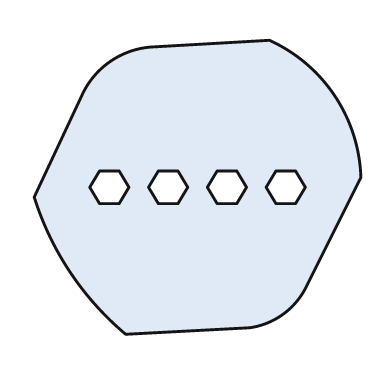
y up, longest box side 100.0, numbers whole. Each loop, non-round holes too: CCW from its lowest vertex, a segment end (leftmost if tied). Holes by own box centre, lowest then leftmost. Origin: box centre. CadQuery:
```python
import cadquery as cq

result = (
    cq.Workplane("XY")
    .moveTo(-22.0, -45.0)
    .lineTo(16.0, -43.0)
    .threePointArc((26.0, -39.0), (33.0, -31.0))
    .lineTo(50.0, 3.0)
    .threePointArc((42.0, 28.0), (22.0, 45.0))
    .lineTo(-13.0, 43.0)
    .threePointArc((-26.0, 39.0), (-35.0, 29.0))
    .lineTo(-50.0, -3.0)
    .threePointArc((-39.0, -26.0), (-22.0, -45.0))
    .close()
    .moveTo(-30.0, -5.0)
    .lineTo(-24.0, -5.0)
    .lineTo(-21.0, 0.0)
    .lineTo(-24.0, 5.0)
    .lineTo(-30.0, 5.0)
    .lineTo(-33.0, 0.0)
    .close()
    .moveTo(-12.0, -5.0)
    .lineTo(-6.0, -5.0)
    .lineTo(-3.0, 0.0)
    .lineTo(-6.0, 5.0)
    .lineTo(-12.0, 5.0)
    .lineTo(-15.0, 0.0)
    .close()
    .moveTo(6.0, -5.0)
    .lineTo(12.0, -5.0)
    .lineTo(15.0, 0.0)
    .lineTo(12.0, 5.0)
    .lineTo(6.0, 5.0)
    .lineTo(3.0, 0.0)
    .close()
    .moveTo(24.0, -5.0)
    .lineTo(30.0, -5.0)
    .lineTo(33.0, 0.0)
    .lineTo(30.0, 5.0)
    .lineTo(24.0, 5.0)
    .lineTo(21.0, 0.0)
    .close()
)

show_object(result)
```